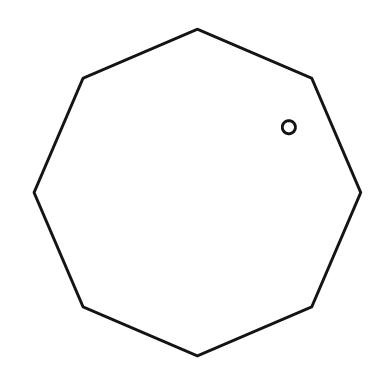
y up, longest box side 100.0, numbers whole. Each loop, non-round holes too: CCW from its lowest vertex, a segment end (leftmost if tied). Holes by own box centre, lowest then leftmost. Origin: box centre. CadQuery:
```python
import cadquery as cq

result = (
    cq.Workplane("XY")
    .moveTo(0.0, -50.0)
    .lineTo(35.0, -35.0)
    .lineTo(50.0, 0.0)
    .lineTo(35.0, 35.0)
    .lineTo(0.0, 50.0)
    .lineTo(-35.0, 35.0)
    .lineTo(-50.0, 0.0)
    .lineTo(-35.0, -35.0)
    .close()
    .moveTo(28.0, 20.0)
    .circle(2.0)
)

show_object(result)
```